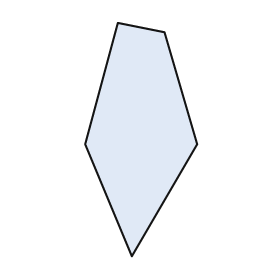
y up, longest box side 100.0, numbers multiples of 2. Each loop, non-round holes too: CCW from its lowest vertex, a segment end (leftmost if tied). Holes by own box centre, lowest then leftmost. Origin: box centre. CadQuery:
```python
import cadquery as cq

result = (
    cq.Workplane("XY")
    .moveTo(-4.0, -50.0)
    .lineTo(24.0, -2.0)
    .lineTo(10.0, 46.0)
    .lineTo(-10.0, 50.0)
    .lineTo(-24.0, -2.0)
    .close()
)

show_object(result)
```